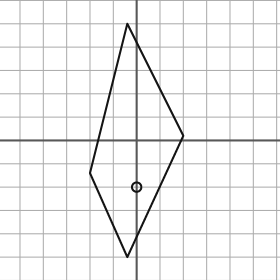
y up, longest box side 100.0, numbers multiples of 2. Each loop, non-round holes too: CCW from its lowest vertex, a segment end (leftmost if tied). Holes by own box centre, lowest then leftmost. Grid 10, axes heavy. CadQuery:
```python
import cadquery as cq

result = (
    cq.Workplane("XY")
    .moveTo(-4.0, -50.0)
    .lineTo(20.0, 2.0)
    .lineTo(-4.0, 50.0)
    .lineTo(-20.0, -14.0)
    .close()
    .moveTo(0.0, -20.0)
    .circle(2.0)
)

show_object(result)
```